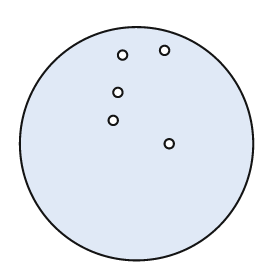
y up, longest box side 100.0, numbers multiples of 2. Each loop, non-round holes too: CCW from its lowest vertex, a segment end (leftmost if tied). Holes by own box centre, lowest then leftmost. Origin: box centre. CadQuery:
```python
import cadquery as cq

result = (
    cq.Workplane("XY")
    .moveTo(0.0, 0.0)
    .circle(50.0)
    .moveTo(14.0, 0.0)
    .circle(2.0)
    .moveTo(-10.0, 10.0)
    .circle(2.0)
    .moveTo(-8.0, 22.0)
    .circle(2.0)
    .moveTo(-6.0, 38.0)
    .circle(2.0)
    .moveTo(12.0, 40.0)
    .circle(2.0)
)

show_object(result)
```